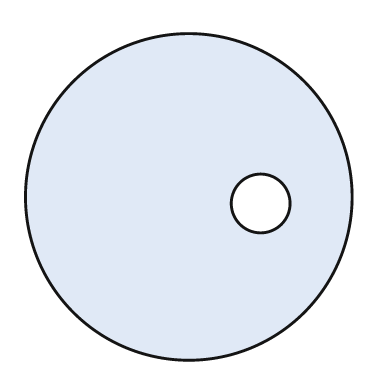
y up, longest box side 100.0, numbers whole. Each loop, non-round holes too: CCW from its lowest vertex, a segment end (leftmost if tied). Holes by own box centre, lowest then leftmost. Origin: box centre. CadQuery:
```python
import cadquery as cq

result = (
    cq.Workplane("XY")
    .moveTo(0.0, 0.0)
    .circle(50.0)
    .moveTo(22.0, -2.0)
    .circle(9.0)
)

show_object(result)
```